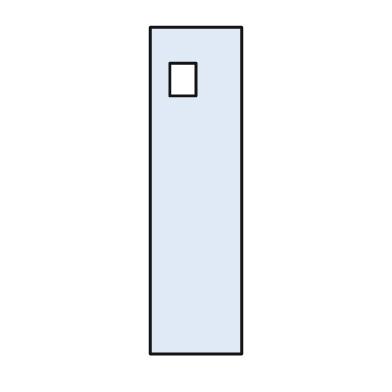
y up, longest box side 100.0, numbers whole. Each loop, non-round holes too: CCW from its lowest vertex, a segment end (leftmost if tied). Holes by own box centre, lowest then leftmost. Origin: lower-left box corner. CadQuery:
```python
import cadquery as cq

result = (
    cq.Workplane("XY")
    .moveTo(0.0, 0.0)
    .lineTo(28.0, 0.0)
    .lineTo(28.0, 100.0)
    .lineTo(0.0, 100.0)
    .close()
    .moveTo(6.0, 79.0)
    .lineTo(14.0, 79.0)
    .lineTo(14.0, 89.0)
    .lineTo(6.0, 89.0)
    .close()
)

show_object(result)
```